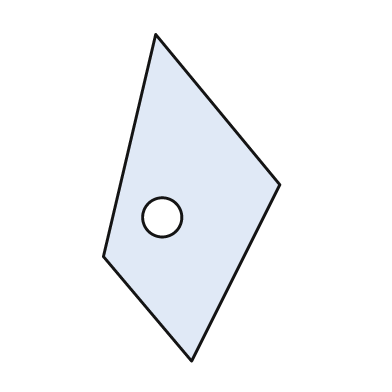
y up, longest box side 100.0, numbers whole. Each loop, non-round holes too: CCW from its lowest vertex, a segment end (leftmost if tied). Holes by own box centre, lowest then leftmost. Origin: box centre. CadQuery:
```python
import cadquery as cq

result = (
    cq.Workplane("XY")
    .moveTo(0.0, -50.0)
    .lineTo(27.0, 4.0)
    .lineTo(-11.0, 50.0)
    .lineTo(-27.0, -18.0)
    .close()
    .moveTo(-9.0, -6.0)
    .circle(6.0)
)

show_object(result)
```